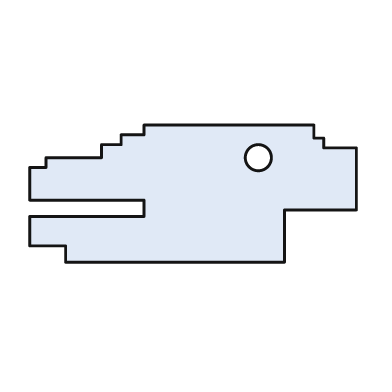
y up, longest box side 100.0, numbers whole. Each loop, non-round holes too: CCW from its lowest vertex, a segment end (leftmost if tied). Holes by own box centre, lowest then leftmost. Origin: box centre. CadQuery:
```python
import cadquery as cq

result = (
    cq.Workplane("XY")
    .moveTo(-39.0, -21.0)
    .lineTo(28.0, -21.0)
    .lineTo(28.0, -5.0)
    .lineTo(50.0, -5.0)
    .lineTo(50.0, 14.0)
    .lineTo(40.0, 14.0)
    .lineTo(40.0, 17.0)
    .lineTo(37.0, 17.0)
    .lineTo(37.0, 21.0)
    .lineTo(-15.0, 21.0)
    .lineTo(-15.0, 18.0)
    .lineTo(-22.0, 18.0)
    .lineTo(-22.0, 15.0)
    .lineTo(-28.0, 15.0)
    .lineTo(-28.0, 11.0)
    .lineTo(-45.0, 11.0)
    .lineTo(-45.0, 8.0)
    .lineTo(-50.0, 8.0)
    .lineTo(-50.0, -2.0)
    .lineTo(-15.0, -2.0)
    .lineTo(-15.0, -7.0)
    .lineTo(-50.0, -7.0)
    .lineTo(-50.0, -16.0)
    .lineTo(-39.0, -16.0)
    .close()
    .moveTo(20.0, 11.0)
    .circle(4.0)
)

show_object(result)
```